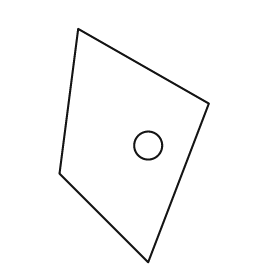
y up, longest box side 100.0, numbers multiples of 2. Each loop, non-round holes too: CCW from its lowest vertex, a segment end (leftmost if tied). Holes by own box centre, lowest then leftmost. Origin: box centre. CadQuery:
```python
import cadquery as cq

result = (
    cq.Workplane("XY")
    .moveTo(6.0, -50.0)
    .lineTo(32.0, 18.0)
    .lineTo(-24.0, 50.0)
    .lineTo(-32.0, -12.0)
    .close()
    .moveTo(6.0, 0.0)
    .circle(6.0)
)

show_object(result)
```